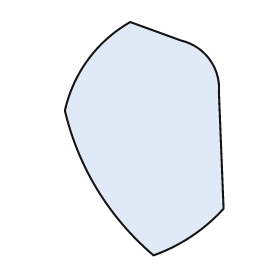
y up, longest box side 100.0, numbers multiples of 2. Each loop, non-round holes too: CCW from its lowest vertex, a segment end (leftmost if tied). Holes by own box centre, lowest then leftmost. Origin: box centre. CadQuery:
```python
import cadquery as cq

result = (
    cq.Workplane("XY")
    .moveTo(4.0, -50.0)
    .threePointArc((20.0, -42.0), (34.0, -30.0))
    .lineTo(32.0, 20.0)
    .threePointArc((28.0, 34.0), (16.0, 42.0))
    .lineTo(-6.0, 50.0)
    .threePointArc((-24.0, 34.0), (-34.0, 12.0))
    .threePointArc((-20.0, -22.0), (4.0, -50.0))
    .close()
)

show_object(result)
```